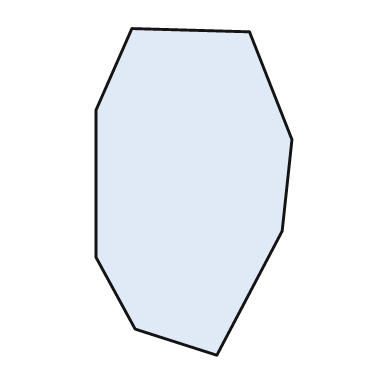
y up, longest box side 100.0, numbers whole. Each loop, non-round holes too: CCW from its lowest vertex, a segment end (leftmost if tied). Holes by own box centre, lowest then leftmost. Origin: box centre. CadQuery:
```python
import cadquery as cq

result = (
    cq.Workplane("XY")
    .moveTo(7.0, -50.0)
    .lineTo(27.0, -12.0)
    .lineTo(30.0, 16.0)
    .lineTo(17.0, 49.0)
    .lineTo(-19.0, 50.0)
    .lineTo(-30.0, 25.0)
    .lineTo(-30.0, -20.0)
    .lineTo(-18.0, -42.0)
    .close()
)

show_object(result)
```